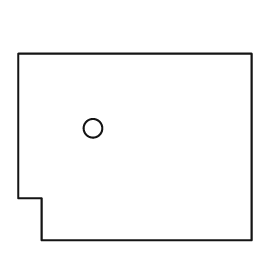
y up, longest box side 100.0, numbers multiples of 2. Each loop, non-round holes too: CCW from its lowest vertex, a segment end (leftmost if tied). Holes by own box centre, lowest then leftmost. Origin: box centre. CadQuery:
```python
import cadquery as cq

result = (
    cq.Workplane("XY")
    .moveTo(-40.0, -40.0)
    .lineTo(50.0, -40.0)
    .lineTo(50.0, 40.0)
    .lineTo(-50.0, 40.0)
    .lineTo(-50.0, -22.0)
    .lineTo(-40.0, -22.0)
    .close()
    .moveTo(-18.0, 8.0)
    .circle(4.0)
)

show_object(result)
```